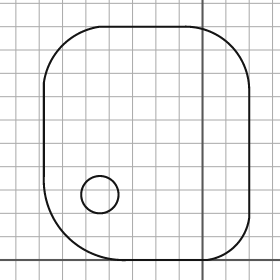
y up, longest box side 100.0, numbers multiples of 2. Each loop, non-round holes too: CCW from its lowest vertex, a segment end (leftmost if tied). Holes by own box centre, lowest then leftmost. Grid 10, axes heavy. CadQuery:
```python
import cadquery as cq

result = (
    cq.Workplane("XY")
    .moveTo(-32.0, 0.0)
    .lineTo(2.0, 0.0)
    .threePointArc((14.0, 6.0), (20.0, 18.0))
    .lineTo(20.0, 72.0)
    .threePointArc((12.0, 92.0), (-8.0, 100.0))
    .lineTo(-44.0, 100.0)
    .threePointArc((-60.0, 92.0), (-68.0, 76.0))
    .lineTo(-68.0, 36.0)
    .threePointArc((-58.0, 10.0), (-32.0, 0.0))
    .close()
    .moveTo(-44.0, 28.0)
    .circle(8.0)
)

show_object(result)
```